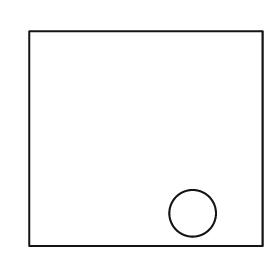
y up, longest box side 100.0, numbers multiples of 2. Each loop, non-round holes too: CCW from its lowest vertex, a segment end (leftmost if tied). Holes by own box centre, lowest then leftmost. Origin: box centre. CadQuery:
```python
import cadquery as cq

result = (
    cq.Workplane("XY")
    .moveTo(-50.0, -46.0)
    .lineTo(50.0, -46.0)
    .lineTo(50.0, 46.0)
    .lineTo(-50.0, 46.0)
    .close()
    .moveTo(20.0, -32.0)
    .circle(10.0)
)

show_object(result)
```